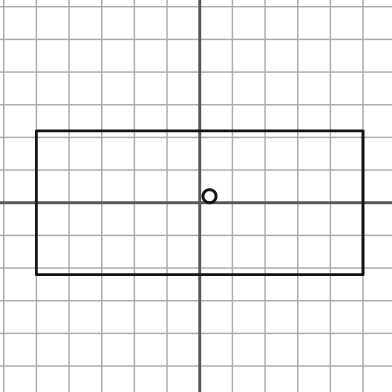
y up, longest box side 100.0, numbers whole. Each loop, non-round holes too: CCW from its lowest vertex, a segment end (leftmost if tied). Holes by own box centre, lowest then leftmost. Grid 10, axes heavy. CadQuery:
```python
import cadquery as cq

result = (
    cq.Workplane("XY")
    .moveTo(-50.0, -22.0)
    .lineTo(50.0, -22.0)
    .lineTo(50.0, 22.0)
    .lineTo(-50.0, 22.0)
    .close()
    .moveTo(3.0, 2.0)
    .circle(2.0)
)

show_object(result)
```